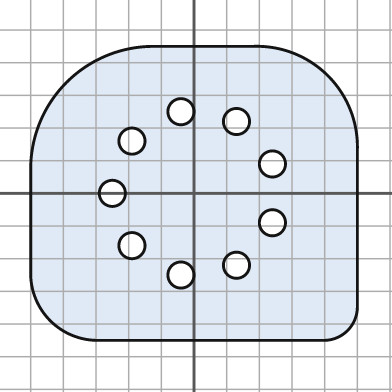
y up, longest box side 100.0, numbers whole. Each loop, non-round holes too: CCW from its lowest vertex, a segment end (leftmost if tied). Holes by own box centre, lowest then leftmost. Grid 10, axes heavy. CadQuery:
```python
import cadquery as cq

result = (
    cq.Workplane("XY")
    .moveTo(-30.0, -45.0)
    .lineTo(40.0, -45.0)
    .threePointArc((47.0, -42.0), (50.0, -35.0))
    .lineTo(50.0, 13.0)
    .threePointArc((41.0, 36.0), (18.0, 45.0))
    .lineTo(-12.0, 45.0)
    .threePointArc((-39.0, 34.0), (-50.0, 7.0))
    .lineTo(-50.0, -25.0)
    .threePointArc((-44.0, -39.0), (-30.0, -45.0))
    .close()
    .moveTo(-4.0, -25.0)
    .circle(4.0)
    .moveTo(13.0, -22.0)
    .circle(4.0)
    .moveTo(-19.0, -16.0)
    .circle(4.0)
    .moveTo(24.0, -9.0)
    .circle(4.0)
    .moveTo(-25.0, 0.0)
    .circle(4.0)
    .moveTo(24.0, 9.0)
    .circle(4.0)
    .moveTo(-19.0, 16.0)
    .circle(4.0)
    .moveTo(13.0, 22.0)
    .circle(4.0)
    .moveTo(-4.0, 25.0)
    .circle(4.0)
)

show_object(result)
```